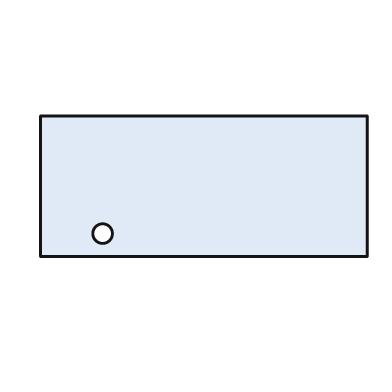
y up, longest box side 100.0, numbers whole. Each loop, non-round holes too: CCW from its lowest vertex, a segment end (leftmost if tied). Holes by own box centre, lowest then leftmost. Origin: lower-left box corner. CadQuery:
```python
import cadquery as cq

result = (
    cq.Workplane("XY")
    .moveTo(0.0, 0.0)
    .lineTo(100.0, 0.0)
    .lineTo(100.0, 43.0)
    .lineTo(0.0, 43.0)
    .close()
    .moveTo(19.0, 7.0)
    .circle(3.0)
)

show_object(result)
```